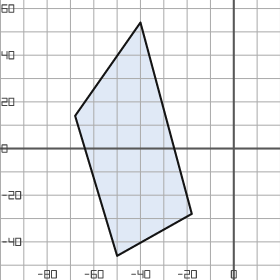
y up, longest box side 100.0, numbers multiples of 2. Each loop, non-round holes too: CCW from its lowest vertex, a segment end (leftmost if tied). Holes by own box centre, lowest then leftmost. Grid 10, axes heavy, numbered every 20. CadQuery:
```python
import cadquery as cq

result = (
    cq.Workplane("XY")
    .moveTo(-50.0, -46.0)
    .lineTo(-18.0, -28.0)
    .lineTo(-40.0, 54.0)
    .lineTo(-68.0, 14.0)
    .close()
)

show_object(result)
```